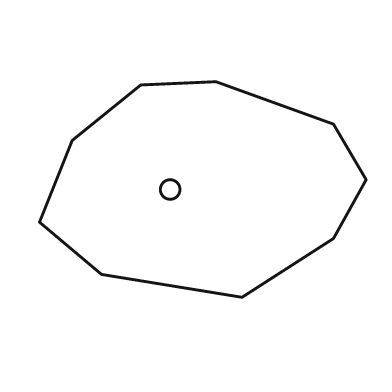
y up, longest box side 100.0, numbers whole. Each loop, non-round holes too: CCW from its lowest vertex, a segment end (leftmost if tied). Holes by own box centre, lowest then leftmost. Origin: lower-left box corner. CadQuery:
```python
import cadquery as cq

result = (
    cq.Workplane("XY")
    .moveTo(62.0, 0.0)
    .lineTo(90.0, 18.0)
    .lineTo(100.0, 36.0)
    .lineTo(90.0, 53.0)
    .lineTo(54.0, 66.0)
    .lineTo(31.0, 65.0)
    .lineTo(10.0, 48.0)
    .lineTo(0.0, 23.0)
    .lineTo(19.0, 7.0)
    .close()
    .moveTo(40.0, 33.0)
    .circle(3.0)
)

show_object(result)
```